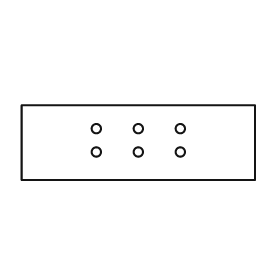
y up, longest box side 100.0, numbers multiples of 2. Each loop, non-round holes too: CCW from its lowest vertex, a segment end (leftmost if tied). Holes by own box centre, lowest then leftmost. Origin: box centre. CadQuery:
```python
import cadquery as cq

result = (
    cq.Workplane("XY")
    .moveTo(-50.0, -16.0)
    .lineTo(50.0, -16.0)
    .lineTo(50.0, 16.0)
    .lineTo(-50.0, 16.0)
    .close()
    .moveTo(-18.0, -4.0)
    .circle(2.0)
    .moveTo(0.0, -4.0)
    .circle(2.0)
    .moveTo(18.0, -4.0)
    .circle(2.0)
    .moveTo(-18.0, 6.0)
    .circle(2.0)
    .moveTo(0.0, 6.0)
    .circle(2.0)
    .moveTo(18.0, 6.0)
    .circle(2.0)
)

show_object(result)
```